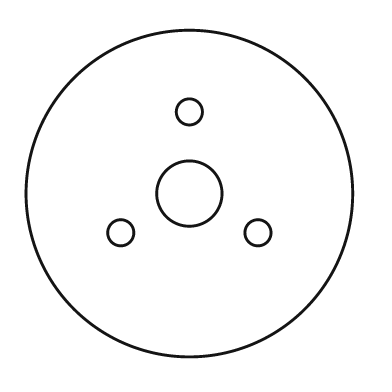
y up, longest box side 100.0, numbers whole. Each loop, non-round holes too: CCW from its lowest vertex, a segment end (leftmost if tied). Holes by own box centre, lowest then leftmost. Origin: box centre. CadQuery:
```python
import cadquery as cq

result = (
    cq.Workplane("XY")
    .moveTo(0.0, 0.0)
    .circle(50.0)
    .moveTo(-21.0, -12.0)
    .circle(4.0)
    .moveTo(21.0, -12.0)
    .circle(4.0)
    .moveTo(0.0, 0.0)
    .circle(10.0)
    .moveTo(0.0, 25.0)
    .circle(4.0)
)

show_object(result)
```